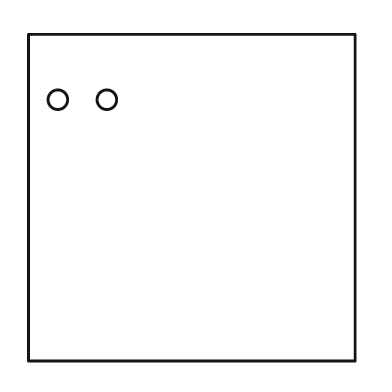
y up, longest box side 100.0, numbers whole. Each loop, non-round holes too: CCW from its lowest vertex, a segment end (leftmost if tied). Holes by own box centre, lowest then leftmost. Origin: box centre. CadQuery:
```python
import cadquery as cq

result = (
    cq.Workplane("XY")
    .moveTo(-50.0, -50.0)
    .lineTo(50.0, -50.0)
    .lineTo(50.0, 50.0)
    .lineTo(-50.0, 50.0)
    .close()
    .moveTo(-41.0, 30.0)
    .circle(3.0)
    .moveTo(-26.0, 30.0)
    .circle(3.0)
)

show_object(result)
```